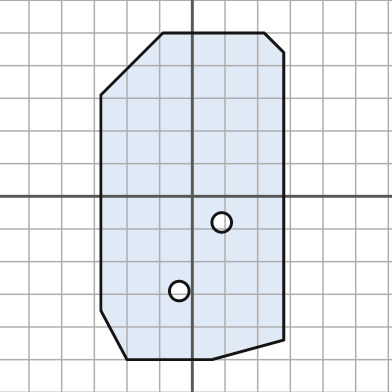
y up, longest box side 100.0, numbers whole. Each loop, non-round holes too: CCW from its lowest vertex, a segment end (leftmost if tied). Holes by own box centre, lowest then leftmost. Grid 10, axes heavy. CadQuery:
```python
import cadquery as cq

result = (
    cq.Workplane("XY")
    .moveTo(-20.0, -50.0)
    .lineTo(6.0, -50.0)
    .lineTo(28.0, -44.0)
    .lineTo(28.0, 44.0)
    .lineTo(22.0, 50.0)
    .lineTo(-9.0, 50.0)
    .lineTo(-28.0, 31.0)
    .lineTo(-28.0, -35.0)
    .close()
    .moveTo(-4.0, -29.0)
    .circle(3.0)
    .moveTo(9.0, -8.0)
    .circle(3.0)
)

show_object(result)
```